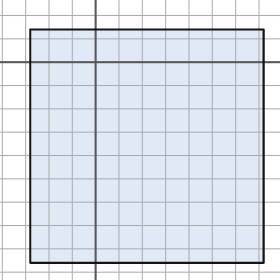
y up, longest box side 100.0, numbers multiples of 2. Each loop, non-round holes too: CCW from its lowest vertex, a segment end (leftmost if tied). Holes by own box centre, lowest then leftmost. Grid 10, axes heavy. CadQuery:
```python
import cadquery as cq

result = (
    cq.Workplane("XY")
    .moveTo(-28.0, -86.0)
    .lineTo(72.0, -86.0)
    .lineTo(72.0, 14.0)
    .lineTo(-28.0, 14.0)
    .close()
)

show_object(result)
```